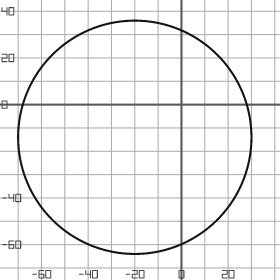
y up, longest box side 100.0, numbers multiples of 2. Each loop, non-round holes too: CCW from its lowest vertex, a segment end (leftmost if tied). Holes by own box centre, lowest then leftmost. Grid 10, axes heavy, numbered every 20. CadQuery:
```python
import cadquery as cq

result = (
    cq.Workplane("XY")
    .moveTo(-20.0, -14.0)
    .circle(50.0)
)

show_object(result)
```